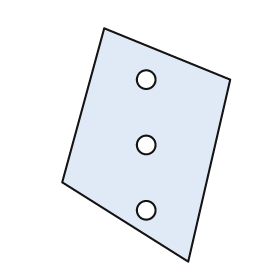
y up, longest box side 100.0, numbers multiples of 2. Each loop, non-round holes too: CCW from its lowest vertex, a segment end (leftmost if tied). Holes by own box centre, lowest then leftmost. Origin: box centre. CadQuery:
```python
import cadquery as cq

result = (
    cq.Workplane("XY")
    .moveTo(18.0, -50.0)
    .lineTo(36.0, 28.0)
    .lineTo(-18.0, 50.0)
    .lineTo(-36.0, -16.0)
    .close()
    .moveTo(0.0, -28.0)
    .circle(4.0)
    .moveTo(0.0, 0.0)
    .circle(4.0)
    .moveTo(0.0, 28.0)
    .circle(4.0)
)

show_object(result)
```